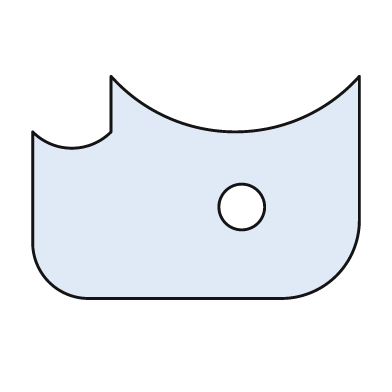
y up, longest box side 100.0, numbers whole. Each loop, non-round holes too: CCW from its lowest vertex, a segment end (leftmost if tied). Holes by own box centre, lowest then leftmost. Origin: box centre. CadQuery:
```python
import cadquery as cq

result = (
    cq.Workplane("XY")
    .moveTo(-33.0, -34.0)
    .lineTo(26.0, -34.0)
    .threePointArc((43.0, -27.0), (50.0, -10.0))
    .lineTo(50.0, 34.0)
    .threePointArc((12.0, 17.0), (-26.0, 34.0))
    .lineTo(-26.0, 17.0)
    .threePointArc((-38.0, 12.0), (-50.0, 17.0))
    .lineTo(-50.0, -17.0)
    .threePointArc((-45.0, -29.0), (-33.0, -34.0))
    .close()
    .moveTo(14.0, -6.0)
    .circle(7.0)
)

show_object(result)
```